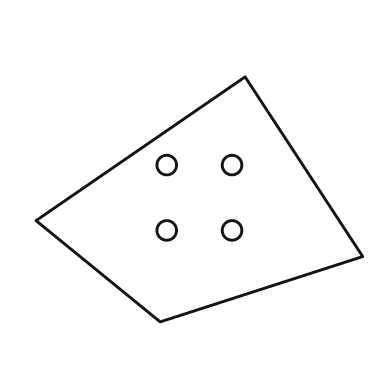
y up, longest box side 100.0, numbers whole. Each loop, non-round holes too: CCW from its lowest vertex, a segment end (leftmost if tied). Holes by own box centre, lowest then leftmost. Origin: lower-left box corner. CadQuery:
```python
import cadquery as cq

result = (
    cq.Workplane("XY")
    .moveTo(38.0, 0.0)
    .lineTo(100.0, 20.0)
    .lineTo(64.0, 75.0)
    .lineTo(0.0, 31.0)
    .close()
    .moveTo(40.0, 28.0)
    .circle(3.0)
    .moveTo(60.0, 28.0)
    .circle(3.0)
    .moveTo(40.0, 48.0)
    .circle(3.0)
    .moveTo(60.0, 48.0)
    .circle(3.0)
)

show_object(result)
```